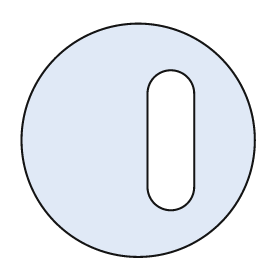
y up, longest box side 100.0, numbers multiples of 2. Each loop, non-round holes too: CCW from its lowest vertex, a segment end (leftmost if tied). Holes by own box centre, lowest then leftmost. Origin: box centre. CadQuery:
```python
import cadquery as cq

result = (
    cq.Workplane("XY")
    .moveTo(0.0, 0.0)
    .circle(50.0)
    .moveTo(4.0, -20.0)
    .threePointArc((14.0, -30.0), (24.0, -20.0))
    .lineTo(24.0, 20.0)
    .threePointArc((14.0, 30.0), (4.0, 20.0))
    .close()
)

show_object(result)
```